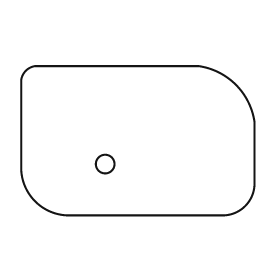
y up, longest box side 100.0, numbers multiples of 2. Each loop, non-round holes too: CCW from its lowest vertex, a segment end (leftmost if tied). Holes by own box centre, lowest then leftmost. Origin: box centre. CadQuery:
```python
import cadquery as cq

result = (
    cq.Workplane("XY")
    .moveTo(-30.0, -32.0)
    .lineTo(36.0, -32.0)
    .threePointArc((46.0, -28.0), (50.0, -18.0))
    .lineTo(50.0, 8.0)
    .threePointArc((42.0, 24.0), (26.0, 32.0))
    .lineTo(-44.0, 32.0)
    .threePointArc((-48.0, 30.0), (-50.0, 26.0))
    .lineTo(-50.0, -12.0)
    .threePointArc((-44.0, -26.0), (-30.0, -32.0))
    .close()
    .moveTo(-14.0, -10.0)
    .circle(4.0)
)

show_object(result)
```